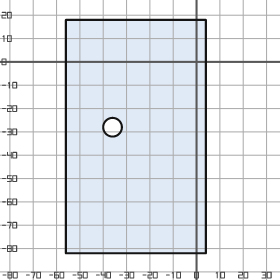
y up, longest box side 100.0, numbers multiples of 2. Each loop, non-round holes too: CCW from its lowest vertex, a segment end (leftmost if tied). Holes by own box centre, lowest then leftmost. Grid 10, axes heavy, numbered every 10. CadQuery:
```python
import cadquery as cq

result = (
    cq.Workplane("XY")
    .moveTo(-56.0, -82.0)
    .lineTo(4.0, -82.0)
    .lineTo(4.0, 18.0)
    .lineTo(-56.0, 18.0)
    .close()
    .moveTo(-36.0, -28.0)
    .circle(4.0)
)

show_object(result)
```